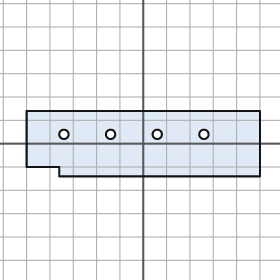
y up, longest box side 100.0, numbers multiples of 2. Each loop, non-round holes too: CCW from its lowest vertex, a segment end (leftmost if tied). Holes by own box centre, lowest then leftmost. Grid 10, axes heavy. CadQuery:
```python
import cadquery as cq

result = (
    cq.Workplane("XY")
    .moveTo(-36.0, -14.0)
    .lineTo(50.0, -14.0)
    .lineTo(50.0, 14.0)
    .lineTo(-50.0, 14.0)
    .lineTo(-50.0, -10.0)
    .lineTo(-36.0, -10.0)
    .close()
    .moveTo(-34.0, 4.0)
    .circle(2.0)
    .moveTo(-14.0, 4.0)
    .circle(2.0)
    .moveTo(6.0, 4.0)
    .circle(2.0)
    .moveTo(26.0, 4.0)
    .circle(2.0)
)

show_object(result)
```